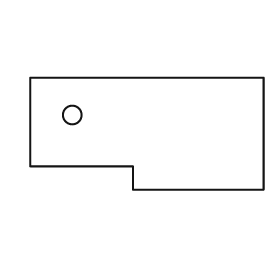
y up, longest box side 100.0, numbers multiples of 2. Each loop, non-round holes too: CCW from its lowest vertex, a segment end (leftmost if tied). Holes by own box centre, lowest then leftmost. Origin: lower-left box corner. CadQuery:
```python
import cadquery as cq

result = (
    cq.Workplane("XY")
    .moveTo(44.0, 0.0)
    .lineTo(100.0, 0.0)
    .lineTo(100.0, 48.0)
    .lineTo(0.0, 48.0)
    .lineTo(0.0, 10.0)
    .lineTo(44.0, 10.0)
    .close()
    .moveTo(18.0, 32.0)
    .circle(4.0)
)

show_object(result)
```